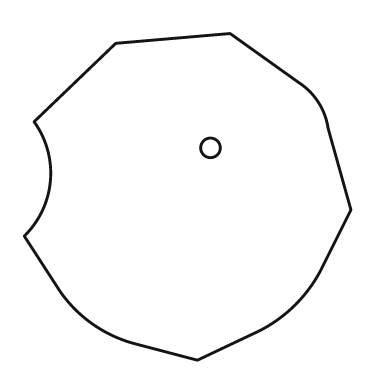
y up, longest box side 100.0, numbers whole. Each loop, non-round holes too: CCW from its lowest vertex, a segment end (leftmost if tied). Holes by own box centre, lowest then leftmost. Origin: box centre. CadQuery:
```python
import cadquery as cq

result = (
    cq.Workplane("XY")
    .moveTo(3.0, -50.0)
    .lineTo(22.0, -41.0)
    .threePointArc((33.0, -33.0), (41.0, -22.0))
    .lineTo(50.0, -4.0)
    .lineTo(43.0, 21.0)
    .threePointArc((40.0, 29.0), (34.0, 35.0))
    .lineTo(13.0, 50.0)
    .lineTo(-22.0, 47.0)
    .lineTo(-47.0, 23.0)
    .threePointArc((-42.0, 5.0), (-50.0, -12.0))
    .lineTo(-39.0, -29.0)
    .threePointArc((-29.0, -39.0), (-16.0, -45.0))
    .close()
    .moveTo(7.0, 15.0)
    .circle(3.0)
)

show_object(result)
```